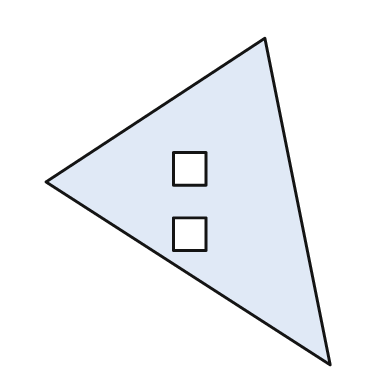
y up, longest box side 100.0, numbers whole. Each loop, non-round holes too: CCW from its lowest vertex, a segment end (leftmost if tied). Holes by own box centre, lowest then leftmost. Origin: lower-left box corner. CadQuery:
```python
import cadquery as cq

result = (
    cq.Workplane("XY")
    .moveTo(87.0, 0.0)
    .lineTo(67.0, 100.0)
    .lineTo(0.0, 56.0)
    .close()
    .moveTo(39.0, 35.0)
    .lineTo(49.0, 35.0)
    .lineTo(49.0, 45.0)
    .lineTo(39.0, 45.0)
    .close()
    .moveTo(39.0, 55.0)
    .lineTo(49.0, 55.0)
    .lineTo(49.0, 65.0)
    .lineTo(39.0, 65.0)
    .close()
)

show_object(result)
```